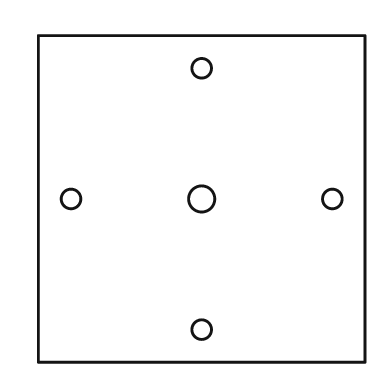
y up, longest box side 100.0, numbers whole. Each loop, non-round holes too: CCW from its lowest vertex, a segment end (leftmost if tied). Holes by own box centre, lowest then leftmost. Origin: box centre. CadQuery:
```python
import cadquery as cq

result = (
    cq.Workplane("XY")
    .moveTo(-50.0, -50.0)
    .lineTo(50.0, -50.0)
    .lineTo(50.0, 50.0)
    .lineTo(-50.0, 50.0)
    .close()
    .moveTo(0.0, -40.0)
    .circle(3.0)
    .moveTo(-40.0, 0.0)
    .circle(3.0)
    .moveTo(0.0, 0.0)
    .circle(4.0)
    .moveTo(40.0, 0.0)
    .circle(3.0)
    .moveTo(0.0, 40.0)
    .circle(3.0)
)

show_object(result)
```